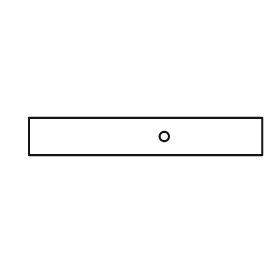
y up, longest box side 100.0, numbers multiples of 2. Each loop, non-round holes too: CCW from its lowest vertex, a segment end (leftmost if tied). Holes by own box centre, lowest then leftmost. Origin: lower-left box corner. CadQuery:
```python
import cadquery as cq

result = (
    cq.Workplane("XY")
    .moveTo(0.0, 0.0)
    .lineTo(100.0, 0.0)
    .lineTo(100.0, 16.0)
    .lineTo(0.0, 16.0)
    .close()
    .moveTo(58.0, 8.0)
    .circle(2.0)
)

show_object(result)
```